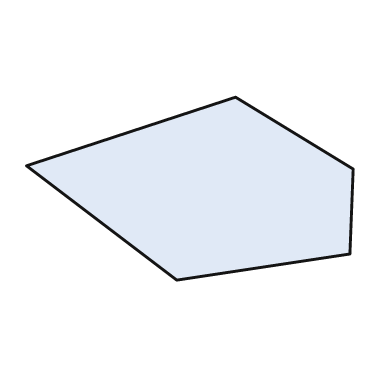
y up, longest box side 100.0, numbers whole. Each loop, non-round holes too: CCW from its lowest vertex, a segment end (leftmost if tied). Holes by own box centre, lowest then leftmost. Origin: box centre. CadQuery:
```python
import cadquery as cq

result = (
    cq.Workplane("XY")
    .moveTo(-4.0, -28.0)
    .lineTo(49.0, -20.0)
    .lineTo(50.0, 6.0)
    .lineTo(14.0, 28.0)
    .lineTo(-50.0, 7.0)
    .close()
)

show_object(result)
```